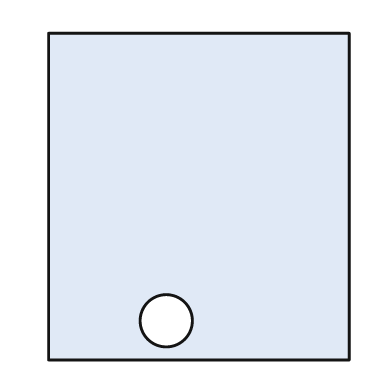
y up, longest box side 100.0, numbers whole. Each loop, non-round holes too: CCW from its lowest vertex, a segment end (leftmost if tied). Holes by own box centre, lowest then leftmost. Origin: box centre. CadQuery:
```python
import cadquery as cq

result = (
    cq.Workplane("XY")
    .moveTo(-46.0, -50.0)
    .lineTo(46.0, -50.0)
    .lineTo(46.0, 50.0)
    .lineTo(-46.0, 50.0)
    .close()
    .moveTo(-10.0, -38.0)
    .circle(8.0)
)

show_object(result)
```